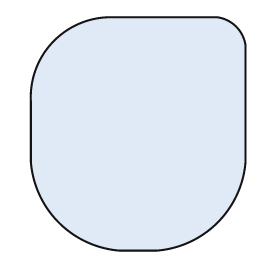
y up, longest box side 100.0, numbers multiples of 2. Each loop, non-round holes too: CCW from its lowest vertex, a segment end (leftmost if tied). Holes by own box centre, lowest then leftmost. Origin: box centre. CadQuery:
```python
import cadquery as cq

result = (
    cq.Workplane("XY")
    .moveTo(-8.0, -50.0)
    .lineTo(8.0, -50.0)
    .threePointArc((34.0, -38.0), (46.0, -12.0))
    .lineTo(46.0, 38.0)
    .threePointArc((42.0, 46.0), (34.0, 50.0))
    .lineTo(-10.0, 50.0)
    .threePointArc((-36.0, 40.0), (-46.0, 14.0))
    .lineTo(-46.0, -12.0)
    .threePointArc((-34.0, -38.0), (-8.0, -50.0))
    .close()
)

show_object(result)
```